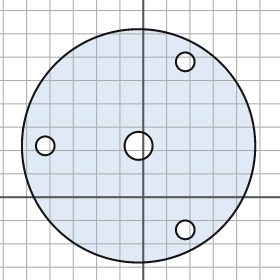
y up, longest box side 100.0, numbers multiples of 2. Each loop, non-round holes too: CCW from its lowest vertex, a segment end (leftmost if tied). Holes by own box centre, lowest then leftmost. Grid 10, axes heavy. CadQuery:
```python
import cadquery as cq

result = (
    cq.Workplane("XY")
    .moveTo(-2.0, 22.0)
    .circle(50.0)
    .moveTo(18.0, -14.0)
    .circle(4.0)
    .moveTo(-42.0, 22.0)
    .circle(4.0)
    .moveTo(-2.0, 22.0)
    .circle(6.0)
    .moveTo(18.0, 58.0)
    .circle(4.0)
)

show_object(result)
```